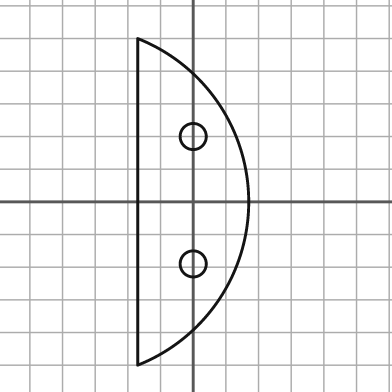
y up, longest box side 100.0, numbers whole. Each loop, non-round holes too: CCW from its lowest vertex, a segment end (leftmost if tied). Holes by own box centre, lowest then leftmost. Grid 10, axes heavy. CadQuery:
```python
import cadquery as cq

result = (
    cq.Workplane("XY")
    .moveTo(-17.0, -50.0)
    .threePointArc((17.0, 0.0), (-17.0, 50.0))
    .close()
    .moveTo(0.0, -19.0)
    .circle(4.0)
    .moveTo(0.0, 20.0)
    .circle(4.0)
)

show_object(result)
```